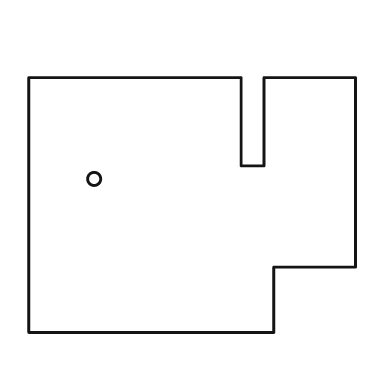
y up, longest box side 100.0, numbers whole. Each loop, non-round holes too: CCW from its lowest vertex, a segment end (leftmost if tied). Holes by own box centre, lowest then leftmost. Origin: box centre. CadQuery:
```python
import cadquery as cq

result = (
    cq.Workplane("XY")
    .moveTo(-50.0, -39.0)
    .lineTo(25.0, -39.0)
    .lineTo(25.0, -19.0)
    .lineTo(50.0, -19.0)
    .lineTo(50.0, 39.0)
    .lineTo(22.0, 39.0)
    .lineTo(22.0, 12.0)
    .lineTo(15.0, 12.0)
    .lineTo(15.0, 39.0)
    .lineTo(-50.0, 39.0)
    .close()
    .moveTo(-30.0, 8.0)
    .circle(2.0)
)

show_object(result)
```